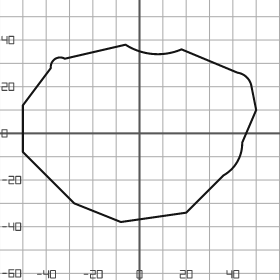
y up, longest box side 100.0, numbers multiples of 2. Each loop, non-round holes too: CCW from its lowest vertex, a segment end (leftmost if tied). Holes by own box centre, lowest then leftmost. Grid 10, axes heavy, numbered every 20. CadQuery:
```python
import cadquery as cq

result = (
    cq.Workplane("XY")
    .moveTo(-8.0, -38.0)
    .lineTo(20.0, -34.0)
    .lineTo(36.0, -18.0)
    .threePointArc((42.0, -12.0), (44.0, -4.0))
    .lineTo(50.0, 10.0)
    .lineTo(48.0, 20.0)
    .threePointArc((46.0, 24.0), (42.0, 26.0))
    .lineTo(18.0, 36.0)
    .threePointArc((6.0, 34.0), (-6.0, 38.0))
    .lineTo(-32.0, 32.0)
    .threePointArc((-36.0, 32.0), (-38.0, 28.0))
    .lineTo(-50.0, 12.0)
    .lineTo(-50.0, -8.0)
    .lineTo(-28.0, -30.0)
    .close()
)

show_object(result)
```